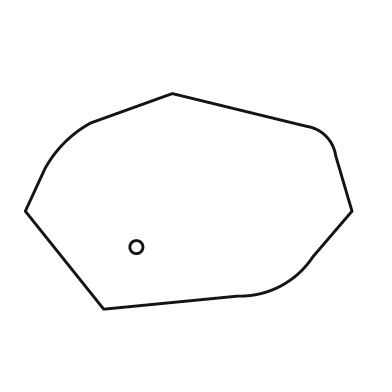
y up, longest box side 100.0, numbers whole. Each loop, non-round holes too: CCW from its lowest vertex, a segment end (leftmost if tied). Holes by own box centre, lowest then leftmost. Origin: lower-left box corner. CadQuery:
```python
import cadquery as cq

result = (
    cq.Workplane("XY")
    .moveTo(24.0, 0.0)
    .lineTo(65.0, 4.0)
    .threePointArc((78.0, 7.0), (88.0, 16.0))
    .lineTo(100.0, 30.0)
    .lineTo(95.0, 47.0)
    .threePointArc((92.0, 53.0), (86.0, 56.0))
    .lineTo(45.0, 66.0)
    .lineTo(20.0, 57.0)
    .threePointArc((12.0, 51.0), (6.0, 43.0))
    .lineTo(0.0, 30.0)
    .close()
    .moveTo(34.0, 19.0)
    .circle(2.0)
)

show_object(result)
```